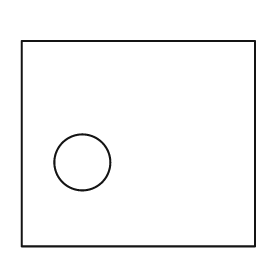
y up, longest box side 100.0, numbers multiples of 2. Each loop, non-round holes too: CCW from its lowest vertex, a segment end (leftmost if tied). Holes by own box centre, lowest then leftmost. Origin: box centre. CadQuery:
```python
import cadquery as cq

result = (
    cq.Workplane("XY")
    .moveTo(-50.0, -44.0)
    .lineTo(50.0, -44.0)
    .lineTo(50.0, 44.0)
    .lineTo(-50.0, 44.0)
    .close()
    .moveTo(-24.0, -8.0)
    .circle(12.0)
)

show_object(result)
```